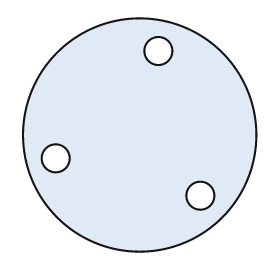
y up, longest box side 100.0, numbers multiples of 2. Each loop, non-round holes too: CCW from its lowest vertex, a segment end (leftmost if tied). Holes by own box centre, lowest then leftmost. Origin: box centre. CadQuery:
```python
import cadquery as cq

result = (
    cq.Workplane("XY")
    .moveTo(0.0, 0.0)
    .circle(50.0)
    .moveTo(26.0, -26.0)
    .circle(6.0)
    .moveTo(-36.0, -10.0)
    .circle(6.0)
    .moveTo(8.0, 36.0)
    .circle(6.0)
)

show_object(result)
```